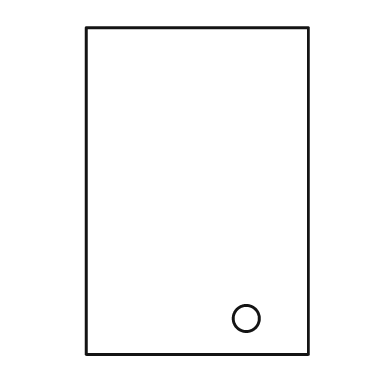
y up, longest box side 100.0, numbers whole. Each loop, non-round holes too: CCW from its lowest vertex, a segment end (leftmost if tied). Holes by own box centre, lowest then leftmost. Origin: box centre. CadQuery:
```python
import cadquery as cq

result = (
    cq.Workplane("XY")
    .moveTo(-34.0, -50.0)
    .lineTo(34.0, -50.0)
    .lineTo(34.0, 50.0)
    .lineTo(-34.0, 50.0)
    .close()
    .moveTo(15.0, -39.0)
    .circle(4.0)
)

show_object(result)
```